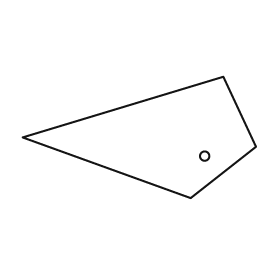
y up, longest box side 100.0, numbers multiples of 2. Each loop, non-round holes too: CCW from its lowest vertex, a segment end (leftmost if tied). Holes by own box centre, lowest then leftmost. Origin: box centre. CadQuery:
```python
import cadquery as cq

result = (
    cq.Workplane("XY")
    .moveTo(22.0, -26.0)
    .lineTo(50.0, -4.0)
    .lineTo(36.0, 26.0)
    .lineTo(-50.0, 0.0)
    .close()
    .moveTo(28.0, -8.0)
    .circle(2.0)
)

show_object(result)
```